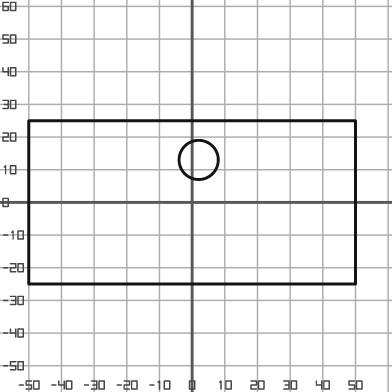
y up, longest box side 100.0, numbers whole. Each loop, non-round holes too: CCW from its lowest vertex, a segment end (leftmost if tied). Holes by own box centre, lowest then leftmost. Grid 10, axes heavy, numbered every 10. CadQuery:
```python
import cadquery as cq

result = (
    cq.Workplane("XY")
    .moveTo(-50.0, -25.0)
    .lineTo(50.0, -25.0)
    .lineTo(50.0, 25.0)
    .lineTo(-50.0, 25.0)
    .close()
    .moveTo(2.0, 13.0)
    .circle(6.0)
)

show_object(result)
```